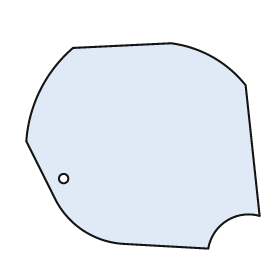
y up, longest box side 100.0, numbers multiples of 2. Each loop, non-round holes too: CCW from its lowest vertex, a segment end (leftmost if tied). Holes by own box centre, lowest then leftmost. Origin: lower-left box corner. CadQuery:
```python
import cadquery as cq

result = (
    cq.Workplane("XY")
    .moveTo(78.0, 0.0)
    .threePointArc((86.0, 12.0), (100.0, 14.0))
    .lineTo(94.0, 70.0)
    .threePointArc((80.0, 82.0), (62.0, 88.0))
    .lineTo(20.0, 86.0)
    .threePointArc((6.0, 68.0), (0.0, 46.0))
    .lineTo(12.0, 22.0)
    .threePointArc((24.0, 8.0), (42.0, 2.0))
    .close()
    .moveTo(16.0, 30.0)
    .circle(2.0)
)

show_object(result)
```